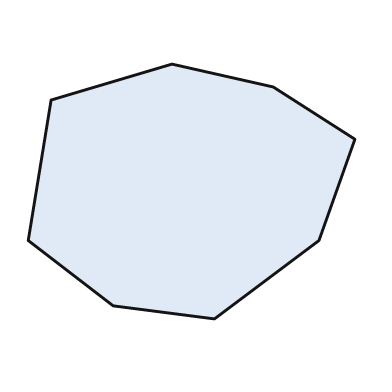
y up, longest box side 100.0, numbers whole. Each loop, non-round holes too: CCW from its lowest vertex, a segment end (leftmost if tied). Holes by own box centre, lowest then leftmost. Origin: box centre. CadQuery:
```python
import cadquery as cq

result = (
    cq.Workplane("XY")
    .moveTo(7.0, -39.0)
    .lineTo(39.0, -15.0)
    .lineTo(50.0, 16.0)
    .lineTo(25.0, 32.0)
    .lineTo(-6.0, 39.0)
    .lineTo(-43.0, 28.0)
    .lineTo(-50.0, -15.0)
    .lineTo(-24.0, -35.0)
    .close()
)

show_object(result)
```